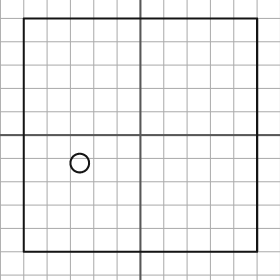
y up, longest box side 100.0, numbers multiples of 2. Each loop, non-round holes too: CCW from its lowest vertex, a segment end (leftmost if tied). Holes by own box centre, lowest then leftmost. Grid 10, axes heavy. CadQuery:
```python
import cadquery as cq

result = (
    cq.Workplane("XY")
    .moveTo(-50.0, -50.0)
    .lineTo(50.0, -50.0)
    .lineTo(50.0, 50.0)
    .lineTo(-50.0, 50.0)
    .close()
    .moveTo(-26.0, -12.0)
    .circle(4.0)
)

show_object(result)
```